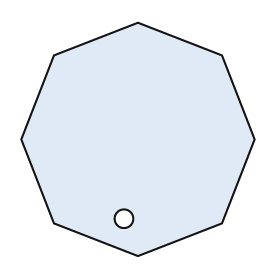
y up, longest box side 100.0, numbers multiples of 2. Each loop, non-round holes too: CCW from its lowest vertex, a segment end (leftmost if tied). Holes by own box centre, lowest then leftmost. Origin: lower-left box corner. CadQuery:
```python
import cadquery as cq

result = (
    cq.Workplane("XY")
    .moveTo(50.0, 0.0)
    .lineTo(86.0, 14.0)
    .lineTo(100.0, 50.0)
    .lineTo(86.0, 86.0)
    .lineTo(50.0, 100.0)
    .lineTo(14.0, 86.0)
    .lineTo(0.0, 50.0)
    .lineTo(14.0, 14.0)
    .close()
    .moveTo(44.0, 16.0)
    .circle(4.0)
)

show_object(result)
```